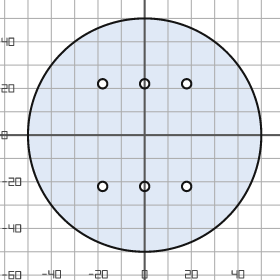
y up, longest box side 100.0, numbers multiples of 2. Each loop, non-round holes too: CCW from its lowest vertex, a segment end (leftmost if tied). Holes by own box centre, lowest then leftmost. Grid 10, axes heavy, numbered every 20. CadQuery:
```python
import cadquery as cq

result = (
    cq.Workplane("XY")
    .moveTo(0.0, 0.0)
    .circle(50.0)
    .moveTo(-18.0, -22.0)
    .circle(2.0)
    .moveTo(0.0, -22.0)
    .circle(2.0)
    .moveTo(18.0, -22.0)
    .circle(2.0)
    .moveTo(-18.0, 22.0)
    .circle(2.0)
    .moveTo(0.0, 22.0)
    .circle(2.0)
    .moveTo(18.0, 22.0)
    .circle(2.0)
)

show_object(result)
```